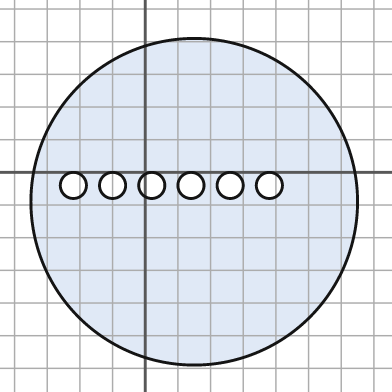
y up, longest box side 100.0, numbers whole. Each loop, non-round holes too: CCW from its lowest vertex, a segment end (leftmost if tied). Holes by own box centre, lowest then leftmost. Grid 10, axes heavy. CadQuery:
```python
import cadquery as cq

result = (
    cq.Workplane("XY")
    .moveTo(15.0, -9.0)
    .circle(50.0)
    .moveTo(-22.0, -4.0)
    .circle(4.0)
    .moveTo(-10.0, -4.0)
    .circle(4.0)
    .moveTo(2.0, -4.0)
    .circle(4.0)
    .moveTo(14.0, -4.0)
    .circle(4.0)
    .moveTo(26.0, -4.0)
    .circle(4.0)
    .moveTo(38.0, -4.0)
    .circle(4.0)
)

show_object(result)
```